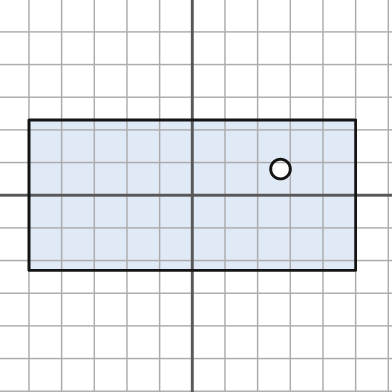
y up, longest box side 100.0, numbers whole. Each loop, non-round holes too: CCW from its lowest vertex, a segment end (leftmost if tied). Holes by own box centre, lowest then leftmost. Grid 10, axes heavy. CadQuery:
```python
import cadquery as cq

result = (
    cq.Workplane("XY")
    .moveTo(-50.0, -23.0)
    .lineTo(50.0, -23.0)
    .lineTo(50.0, 23.0)
    .lineTo(-50.0, 23.0)
    .close()
    .moveTo(27.0, 8.0)
    .circle(3.0)
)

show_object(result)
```